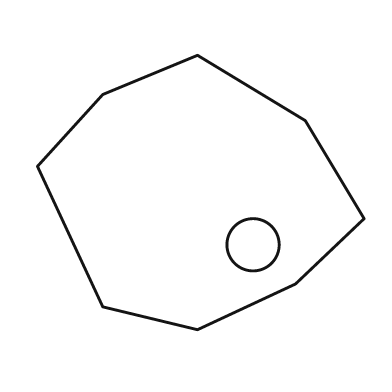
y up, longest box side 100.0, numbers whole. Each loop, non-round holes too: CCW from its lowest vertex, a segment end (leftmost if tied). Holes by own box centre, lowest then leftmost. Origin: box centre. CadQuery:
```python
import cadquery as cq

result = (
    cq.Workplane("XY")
    .moveTo(-1.0, -42.0)
    .lineTo(29.0, -28.0)
    .lineTo(50.0, -8.0)
    .lineTo(32.0, 22.0)
    .lineTo(-1.0, 42.0)
    .lineTo(-30.0, 30.0)
    .lineTo(-50.0, 8.0)
    .lineTo(-30.0, -35.0)
    .close()
    .moveTo(16.0, -16.0)
    .circle(8.0)
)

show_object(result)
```